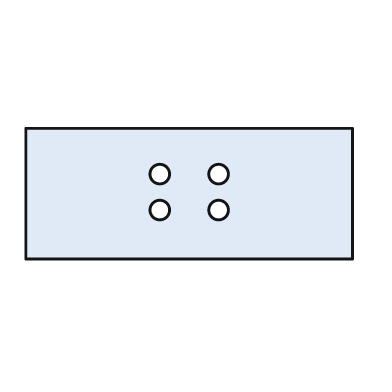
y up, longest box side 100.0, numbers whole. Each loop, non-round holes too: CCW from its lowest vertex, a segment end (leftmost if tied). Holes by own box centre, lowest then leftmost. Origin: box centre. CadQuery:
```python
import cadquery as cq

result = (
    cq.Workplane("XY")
    .moveTo(-50.0, -20.0)
    .lineTo(50.0, -20.0)
    .lineTo(50.0, 20.0)
    .lineTo(-50.0, 20.0)
    .close()
    .moveTo(-9.0, -5.0)
    .circle(3.0)
    .moveTo(9.0, -5.0)
    .circle(3.0)
    .moveTo(-9.0, 6.0)
    .circle(3.0)
    .moveTo(9.0, 6.0)
    .circle(3.0)
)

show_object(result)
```